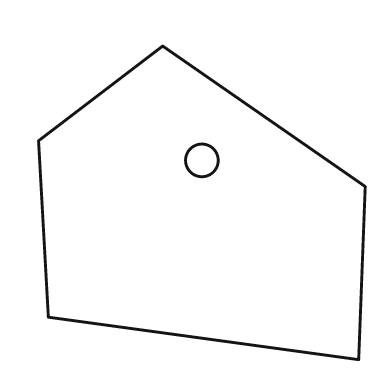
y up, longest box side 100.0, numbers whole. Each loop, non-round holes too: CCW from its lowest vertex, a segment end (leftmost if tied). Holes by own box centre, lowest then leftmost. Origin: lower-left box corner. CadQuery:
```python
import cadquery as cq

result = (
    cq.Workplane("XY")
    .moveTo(98.0, 0.0)
    .lineTo(100.0, 53.0)
    .lineTo(38.0, 96.0)
    .lineTo(0.0, 67.0)
    .lineTo(3.0, 13.0)
    .close()
    .moveTo(50.0, 61.0)
    .circle(5.0)
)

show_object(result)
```